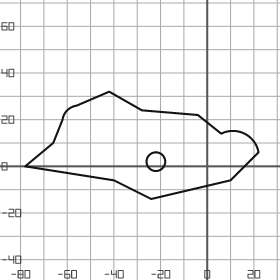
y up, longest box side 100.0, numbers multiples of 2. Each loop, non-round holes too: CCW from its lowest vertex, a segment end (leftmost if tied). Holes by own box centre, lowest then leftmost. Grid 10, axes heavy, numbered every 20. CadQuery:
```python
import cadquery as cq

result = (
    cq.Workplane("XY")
    .moveTo(-24.0, -14.0)
    .lineTo(10.0, -6.0)
    .lineTo(22.0, 6.0)
    .threePointArc((16.0, 14.0), (6.0, 14.0))
    .lineTo(-4.0, 22.0)
    .lineTo(-28.0, 24.0)
    .lineTo(-42.0, 32.0)
    .lineTo(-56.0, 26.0)
    .threePointArc((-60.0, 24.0), (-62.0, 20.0))
    .lineTo(-66.0, 10.0)
    .lineTo(-78.0, 0.0)
    .lineTo(-40.0, -6.0)
    .close()
    .moveTo(-22.0, 2.0)
    .circle(4.0)
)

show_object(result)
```